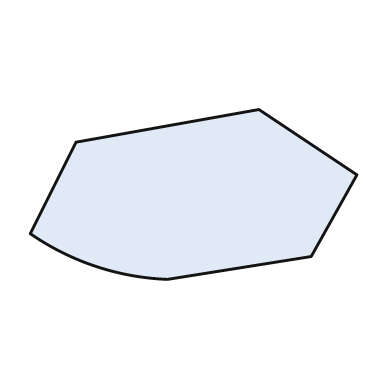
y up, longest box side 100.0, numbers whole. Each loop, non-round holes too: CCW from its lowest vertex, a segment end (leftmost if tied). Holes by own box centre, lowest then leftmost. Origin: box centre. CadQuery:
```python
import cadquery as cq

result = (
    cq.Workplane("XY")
    .moveTo(-8.0, -26.0)
    .lineTo(36.0, -19.0)
    .lineTo(50.0, 6.0)
    .lineTo(20.0, 26.0)
    .lineTo(-36.0, 16.0)
    .lineTo(-50.0, -12.0)
    .threePointArc((-30.0, -22.0), (-8.0, -26.0))
    .close()
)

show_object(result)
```